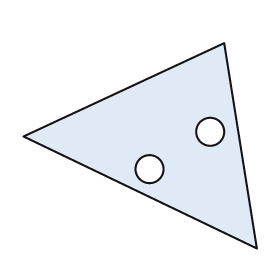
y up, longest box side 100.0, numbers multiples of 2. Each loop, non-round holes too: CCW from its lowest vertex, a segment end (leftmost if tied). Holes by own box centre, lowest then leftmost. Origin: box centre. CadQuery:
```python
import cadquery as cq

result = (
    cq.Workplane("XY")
    .moveTo(50.0, -44.0)
    .lineTo(36.0, 44.0)
    .lineTo(-50.0, 4.0)
    .close()
    .moveTo(4.0, -10.0)
    .circle(6.0)
    .moveTo(30.0, 6.0)
    .circle(6.0)
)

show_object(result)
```